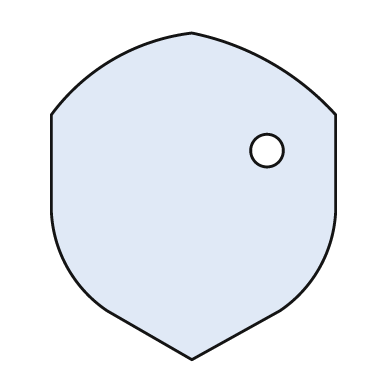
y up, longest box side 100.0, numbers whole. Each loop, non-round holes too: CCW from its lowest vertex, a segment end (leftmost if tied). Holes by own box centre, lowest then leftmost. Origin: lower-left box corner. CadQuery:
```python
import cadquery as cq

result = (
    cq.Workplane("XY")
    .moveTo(43.0, 0.0)
    .lineTo(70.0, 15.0)
    .threePointArc((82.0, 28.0), (87.0, 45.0))
    .lineTo(87.0, 75.0)
    .threePointArc((67.0, 91.0), (43.0, 100.0))
    .threePointArc((19.0, 92.0), (0.0, 75.0))
    .lineTo(0.0, 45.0)
    .threePointArc((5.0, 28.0), (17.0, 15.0))
    .close()
    .moveTo(66.0, 64.0)
    .circle(5.0)
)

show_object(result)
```